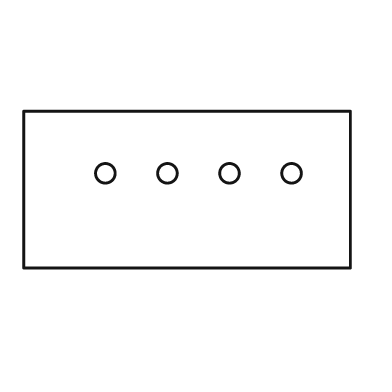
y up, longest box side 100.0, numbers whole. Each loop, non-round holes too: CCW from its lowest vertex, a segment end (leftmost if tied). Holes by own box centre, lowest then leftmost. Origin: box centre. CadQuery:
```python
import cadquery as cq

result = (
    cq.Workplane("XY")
    .moveTo(-50.0, -24.0)
    .lineTo(50.0, -24.0)
    .lineTo(50.0, 24.0)
    .lineTo(-50.0, 24.0)
    .close()
    .moveTo(-25.0, 5.0)
    .circle(3.0)
    .moveTo(-6.0, 5.0)
    .circle(3.0)
    .moveTo(13.0, 5.0)
    .circle(3.0)
    .moveTo(32.0, 5.0)
    .circle(3.0)
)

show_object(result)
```